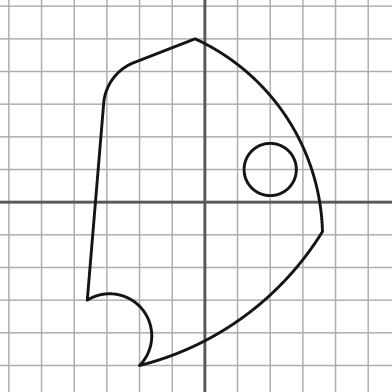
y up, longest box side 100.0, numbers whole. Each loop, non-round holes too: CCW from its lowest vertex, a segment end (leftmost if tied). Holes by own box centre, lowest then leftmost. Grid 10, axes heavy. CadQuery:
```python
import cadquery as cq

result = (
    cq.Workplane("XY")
    .moveTo(-20.0, -50.0)
    .threePointArc((12.0, -35.0), (36.0, -9.0))
    .threePointArc((25.0, 26.0), (-3.0, 50.0))
    .lineTo(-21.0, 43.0)
    .threePointArc((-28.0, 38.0), (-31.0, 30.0))
    .lineTo(-36.0, -30.0)
    .threePointArc((-19.0, -33.0), (-20.0, -50.0))
    .close()
    .moveTo(20.0, 10.0)
    .circle(8.0)
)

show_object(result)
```